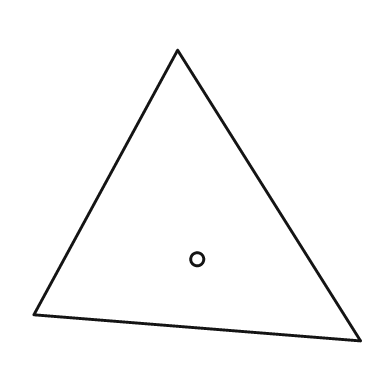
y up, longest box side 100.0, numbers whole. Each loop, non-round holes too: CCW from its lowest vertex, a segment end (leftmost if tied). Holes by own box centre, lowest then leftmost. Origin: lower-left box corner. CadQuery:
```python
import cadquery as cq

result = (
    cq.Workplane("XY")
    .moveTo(100.0, 0.0)
    .lineTo(44.0, 89.0)
    .lineTo(0.0, 8.0)
    .close()
    .moveTo(50.0, 25.0)
    .circle(2.0)
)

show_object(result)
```